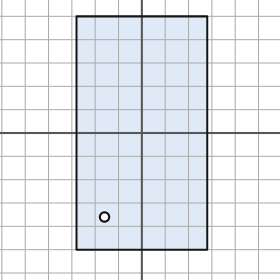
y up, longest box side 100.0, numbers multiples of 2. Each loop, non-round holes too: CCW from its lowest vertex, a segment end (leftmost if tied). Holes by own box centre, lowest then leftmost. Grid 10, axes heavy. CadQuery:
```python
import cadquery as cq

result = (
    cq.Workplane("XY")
    .moveTo(-28.0, -50.0)
    .lineTo(28.0, -50.0)
    .lineTo(28.0, 50.0)
    .lineTo(-28.0, 50.0)
    .close()
    .moveTo(-16.0, -36.0)
    .circle(2.0)
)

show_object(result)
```